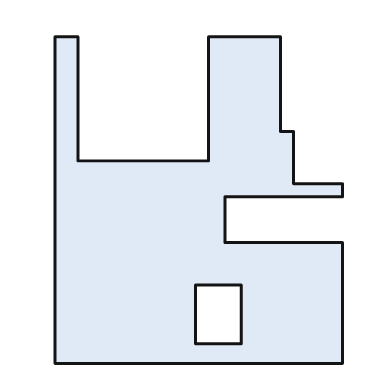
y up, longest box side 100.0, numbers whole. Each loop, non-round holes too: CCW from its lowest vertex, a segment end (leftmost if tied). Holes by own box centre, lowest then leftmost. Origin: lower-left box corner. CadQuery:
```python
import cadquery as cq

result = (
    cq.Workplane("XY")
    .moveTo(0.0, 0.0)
    .lineTo(88.0, 0.0)
    .lineTo(88.0, 37.0)
    .lineTo(52.0, 37.0)
    .lineTo(52.0, 51.0)
    .lineTo(88.0, 51.0)
    .lineTo(88.0, 55.0)
    .lineTo(73.0, 55.0)
    .lineTo(73.0, 71.0)
    .lineTo(69.0, 71.0)
    .lineTo(69.0, 100.0)
    .lineTo(47.0, 100.0)
    .lineTo(47.0, 62.0)
    .lineTo(7.0, 62.0)
    .lineTo(7.0, 100.0)
    .lineTo(0.0, 100.0)
    .close()
    .moveTo(43.0, 6.0)
    .lineTo(57.0, 6.0)
    .lineTo(57.0, 24.0)
    .lineTo(43.0, 24.0)
    .close()
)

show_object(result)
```